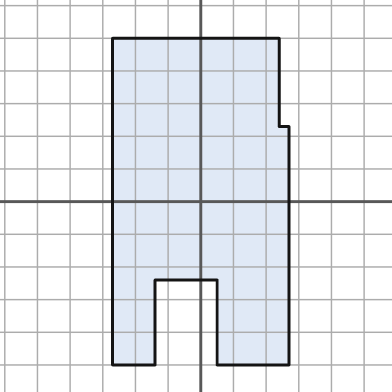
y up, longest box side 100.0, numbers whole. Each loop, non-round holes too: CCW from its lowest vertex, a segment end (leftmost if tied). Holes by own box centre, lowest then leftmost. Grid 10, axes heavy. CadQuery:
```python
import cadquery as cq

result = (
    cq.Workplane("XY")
    .moveTo(-27.0, -50.0)
    .lineTo(-14.0, -50.0)
    .lineTo(-14.0, -24.0)
    .lineTo(5.0, -24.0)
    .lineTo(5.0, -50.0)
    .lineTo(27.0, -50.0)
    .lineTo(27.0, 23.0)
    .lineTo(24.0, 23.0)
    .lineTo(24.0, 50.0)
    .lineTo(-27.0, 50.0)
    .close()
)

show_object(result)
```